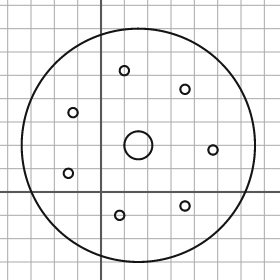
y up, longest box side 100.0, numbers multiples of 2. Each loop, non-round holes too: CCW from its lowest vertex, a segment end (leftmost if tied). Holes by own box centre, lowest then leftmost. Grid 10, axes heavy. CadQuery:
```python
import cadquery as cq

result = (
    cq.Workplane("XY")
    .moveTo(16.0, 20.0)
    .circle(50.0)
    .moveTo(8.0, -10.0)
    .circle(2.0)
    .moveTo(36.0, -6.0)
    .circle(2.0)
    .moveTo(-14.0, 8.0)
    .circle(2.0)
    .moveTo(48.0, 18.0)
    .circle(2.0)
    .moveTo(16.0, 20.0)
    .circle(6.0)
    .moveTo(-12.0, 34.0)
    .circle(2.0)
    .moveTo(36.0, 44.0)
    .circle(2.0)
    .moveTo(10.0, 52.0)
    .circle(2.0)
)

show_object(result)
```